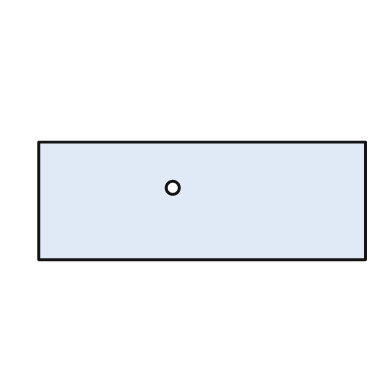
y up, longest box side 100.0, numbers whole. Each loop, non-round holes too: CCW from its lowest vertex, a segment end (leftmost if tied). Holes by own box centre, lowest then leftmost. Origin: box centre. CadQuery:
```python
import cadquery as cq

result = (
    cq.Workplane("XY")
    .moveTo(-50.0, -18.0)
    .lineTo(50.0, -18.0)
    .lineTo(50.0, 18.0)
    .lineTo(-50.0, 18.0)
    .close()
    .moveTo(-9.0, 4.0)
    .circle(2.0)
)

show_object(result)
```